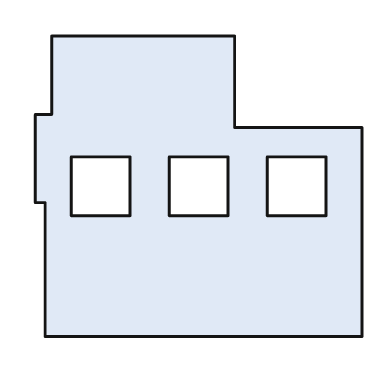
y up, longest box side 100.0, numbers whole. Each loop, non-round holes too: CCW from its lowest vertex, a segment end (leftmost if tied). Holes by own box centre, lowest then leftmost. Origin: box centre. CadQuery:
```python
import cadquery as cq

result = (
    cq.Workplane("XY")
    .moveTo(-47.0, -46.0)
    .lineTo(50.0, -46.0)
    .lineTo(50.0, 18.0)
    .lineTo(11.0, 18.0)
    .lineTo(11.0, 46.0)
    .lineTo(-45.0, 46.0)
    .lineTo(-45.0, 22.0)
    .lineTo(-50.0, 22.0)
    .lineTo(-50.0, -5.0)
    .lineTo(-47.0, -5.0)
    .close()
    .moveTo(-39.0, -9.0)
    .lineTo(-21.0, -9.0)
    .lineTo(-21.0, 9.0)
    .lineTo(-39.0, 9.0)
    .close()
    .moveTo(-9.0, -9.0)
    .lineTo(9.0, -9.0)
    .lineTo(9.0, 9.0)
    .lineTo(-9.0, 9.0)
    .close()
    .moveTo(21.0, -9.0)
    .lineTo(39.0, -9.0)
    .lineTo(39.0, 9.0)
    .lineTo(21.0, 9.0)
    .close()
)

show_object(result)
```